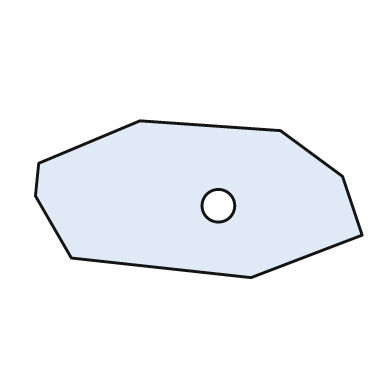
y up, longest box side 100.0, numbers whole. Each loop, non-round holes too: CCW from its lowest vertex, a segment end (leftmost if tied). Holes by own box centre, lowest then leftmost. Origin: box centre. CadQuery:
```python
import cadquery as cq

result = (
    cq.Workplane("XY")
    .moveTo(16.0, -24.0)
    .lineTo(50.0, -11.0)
    .lineTo(44.0, 7.0)
    .lineTo(25.0, 21.0)
    .lineTo(-18.0, 24.0)
    .lineTo(-49.0, 11.0)
    .lineTo(-50.0, 1.0)
    .lineTo(-39.0, -18.0)
    .close()
    .moveTo(6.0, -2.0)
    .circle(5.0)
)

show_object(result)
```